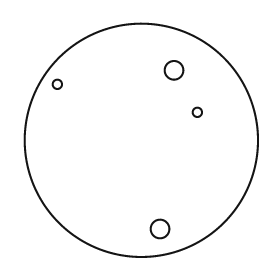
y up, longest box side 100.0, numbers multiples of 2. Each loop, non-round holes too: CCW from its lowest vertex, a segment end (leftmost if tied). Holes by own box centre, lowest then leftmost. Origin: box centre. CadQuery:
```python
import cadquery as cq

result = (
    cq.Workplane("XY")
    .moveTo(0.0, 0.0)
    .circle(50.0)
    .moveTo(8.0, -38.0)
    .circle(4.0)
    .moveTo(24.0, 12.0)
    .circle(2.0)
    .moveTo(-36.0, 24.0)
    .circle(2.0)
    .moveTo(14.0, 30.0)
    .circle(4.0)
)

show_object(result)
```